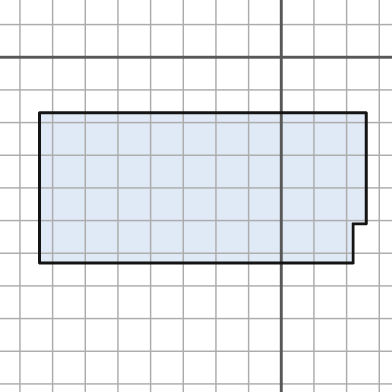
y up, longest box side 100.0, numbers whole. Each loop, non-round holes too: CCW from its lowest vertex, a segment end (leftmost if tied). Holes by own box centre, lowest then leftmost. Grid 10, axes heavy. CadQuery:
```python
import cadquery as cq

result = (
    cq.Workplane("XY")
    .moveTo(-74.0, -63.0)
    .lineTo(22.0, -63.0)
    .lineTo(22.0, -51.0)
    .lineTo(26.0, -51.0)
    .lineTo(26.0, -17.0)
    .lineTo(-74.0, -17.0)
    .close()
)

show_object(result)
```